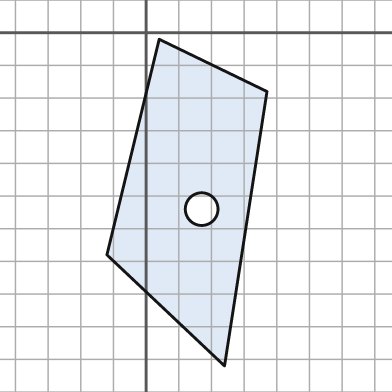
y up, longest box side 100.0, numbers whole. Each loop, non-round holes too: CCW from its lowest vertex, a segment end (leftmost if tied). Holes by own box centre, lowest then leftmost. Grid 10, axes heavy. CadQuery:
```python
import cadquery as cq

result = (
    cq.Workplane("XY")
    .moveTo(24.0, -102.0)
    .lineTo(37.0, -18.0)
    .lineTo(4.0, -2.0)
    .lineTo(-12.0, -68.0)
    .close()
    .moveTo(17.0, -54.0)
    .circle(5.0)
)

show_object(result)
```